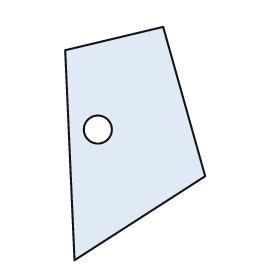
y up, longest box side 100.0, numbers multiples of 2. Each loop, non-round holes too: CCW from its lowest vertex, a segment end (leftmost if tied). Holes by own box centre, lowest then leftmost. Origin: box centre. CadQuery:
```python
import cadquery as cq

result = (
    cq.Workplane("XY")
    .moveTo(-26.0, -50.0)
    .lineTo(30.0, -14.0)
    .lineTo(12.0, 50.0)
    .lineTo(-30.0, 40.0)
    .close()
    .moveTo(-16.0, 6.0)
    .circle(6.0)
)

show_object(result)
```